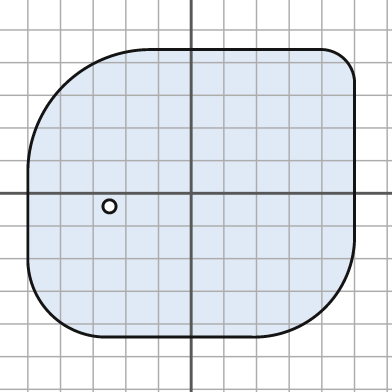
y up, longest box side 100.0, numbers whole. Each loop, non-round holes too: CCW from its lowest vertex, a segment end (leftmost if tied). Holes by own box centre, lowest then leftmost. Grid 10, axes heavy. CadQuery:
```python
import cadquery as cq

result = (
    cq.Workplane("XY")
    .moveTo(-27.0, -44.0)
    .lineTo(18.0, -44.0)
    .threePointArc((41.0, -35.0), (50.0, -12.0))
    .lineTo(50.0, 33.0)
    .threePointArc((47.0, 41.0), (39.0, 44.0))
    .lineTo(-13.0, 44.0)
    .threePointArc((-39.0, 33.0), (-50.0, 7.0))
    .lineTo(-50.0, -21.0)
    .threePointArc((-43.0, -37.0), (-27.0, -44.0))
    .close()
    .moveTo(-25.0, -4.0)
    .circle(2.0)
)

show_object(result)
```